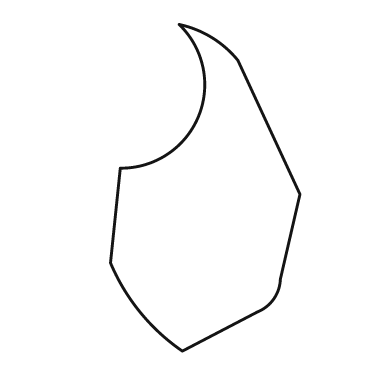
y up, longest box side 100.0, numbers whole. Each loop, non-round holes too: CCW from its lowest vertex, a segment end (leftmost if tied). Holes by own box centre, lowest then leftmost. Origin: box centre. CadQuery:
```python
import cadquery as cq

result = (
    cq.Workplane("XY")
    .moveTo(-7.0, -50.0)
    .lineTo(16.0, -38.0)
    .threePointArc((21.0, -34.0), (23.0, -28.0))
    .lineTo(29.0, -2.0)
    .lineTo(10.0, 39.0)
    .threePointArc((2.0, 46.0), (-8.0, 50.0))
    .threePointArc((-2.0, 22.0), (-26.0, 6.0))
    .lineTo(-29.0, -23.0)
    .threePointArc((-20.0, -38.0), (-7.0, -50.0))
    .close()
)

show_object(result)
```